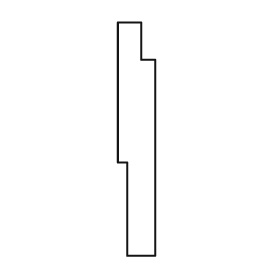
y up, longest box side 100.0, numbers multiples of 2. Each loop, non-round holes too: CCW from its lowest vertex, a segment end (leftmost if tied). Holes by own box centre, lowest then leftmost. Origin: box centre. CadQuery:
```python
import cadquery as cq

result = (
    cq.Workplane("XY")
    .moveTo(-4.0, -50.0)
    .lineTo(8.0, -50.0)
    .lineTo(8.0, 34.0)
    .lineTo(2.0, 34.0)
    .lineTo(2.0, 50.0)
    .lineTo(-8.0, 50.0)
    .lineTo(-8.0, -10.0)
    .lineTo(-4.0, -10.0)
    .close()
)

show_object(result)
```